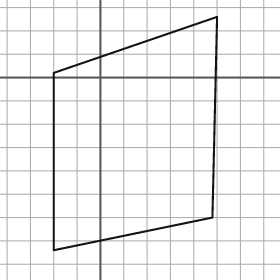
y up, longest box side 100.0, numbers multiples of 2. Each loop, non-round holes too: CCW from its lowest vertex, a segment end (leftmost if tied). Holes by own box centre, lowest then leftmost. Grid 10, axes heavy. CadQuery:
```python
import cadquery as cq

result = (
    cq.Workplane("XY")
    .moveTo(-20.0, -74.0)
    .lineTo(48.0, -60.0)
    .lineTo(50.0, 26.0)
    .lineTo(-20.0, 2.0)
    .close()
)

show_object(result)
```